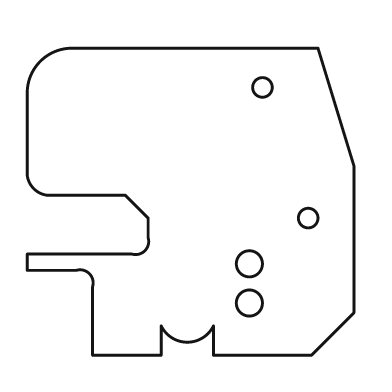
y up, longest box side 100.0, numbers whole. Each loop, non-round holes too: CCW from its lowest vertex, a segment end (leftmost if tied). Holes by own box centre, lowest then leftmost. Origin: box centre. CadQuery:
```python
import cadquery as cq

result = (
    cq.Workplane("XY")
    .moveTo(-30.0, -47.0)
    .lineTo(-9.0, -47.0)
    .lineTo(-9.0, -38.0)
    .threePointArc((-1.0, -43.0), (7.0, -38.0))
    .lineTo(7.0, -47.0)
    .lineTo(37.0, -47.0)
    .lineTo(50.0, -34.0)
    .lineTo(50.0, 11.0)
    .lineTo(39.0, 47.0)
    .lineTo(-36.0, 47.0)
    .threePointArc((-46.0, 43.0), (-50.0, 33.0))
    .lineTo(-50.0, 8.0)
    .threePointArc((-48.0, 4.0), (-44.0, 2.0))
    .lineTo(-20.0, 2.0)
    .lineTo(-13.0, -5.0)
    .lineTo(-13.0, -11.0)
    .threePointArc((-14.0, -15.0), (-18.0, -16.0))
    .lineTo(-50.0, -16.0)
    .lineTo(-50.0, -21.0)
    .lineTo(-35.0, -21.0)
    .threePointArc((-31.0, -22.0), (-30.0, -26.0))
    .close()
    .moveTo(18.0, -31.0)
    .circle(4.0)
    .moveTo(18.0, -19.0)
    .circle(4.0)
    .moveTo(36.0, -5.0)
    .circle(3.0)
    .moveTo(22.0, 35.0)
    .circle(3.0)
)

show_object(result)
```